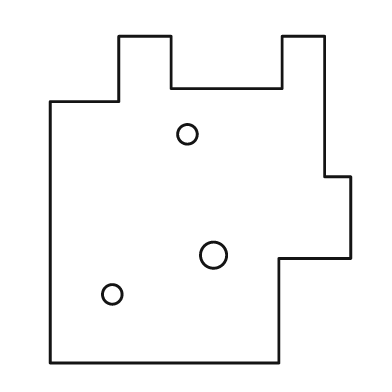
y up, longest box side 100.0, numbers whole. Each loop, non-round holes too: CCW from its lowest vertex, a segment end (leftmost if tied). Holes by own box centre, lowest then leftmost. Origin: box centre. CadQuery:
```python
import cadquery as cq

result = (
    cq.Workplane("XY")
    .moveTo(-46.0, -50.0)
    .lineTo(24.0, -50.0)
    .lineTo(24.0, -18.0)
    .lineTo(46.0, -18.0)
    .lineTo(46.0, 7.0)
    .lineTo(38.0, 7.0)
    .lineTo(38.0, 50.0)
    .lineTo(25.0, 50.0)
    .lineTo(25.0, 34.0)
    .lineTo(-9.0, 34.0)
    .lineTo(-9.0, 50.0)
    .lineTo(-25.0, 50.0)
    .lineTo(-25.0, 30.0)
    .lineTo(-46.0, 30.0)
    .close()
    .moveTo(-27.0, -29.0)
    .circle(3.0)
    .moveTo(4.0, -17.0)
    .circle(4.0)
    .moveTo(-4.0, 20.0)
    .circle(3.0)
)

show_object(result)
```